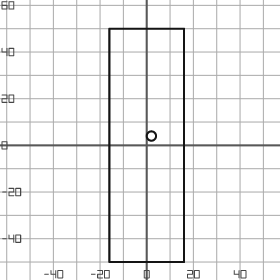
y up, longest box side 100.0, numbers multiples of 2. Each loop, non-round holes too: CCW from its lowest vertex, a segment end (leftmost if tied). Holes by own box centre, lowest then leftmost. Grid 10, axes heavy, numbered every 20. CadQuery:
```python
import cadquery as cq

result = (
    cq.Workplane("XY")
    .moveTo(-16.0, -50.0)
    .lineTo(16.0, -50.0)
    .lineTo(16.0, 50.0)
    .lineTo(-16.0, 50.0)
    .close()
    .moveTo(2.0, 4.0)
    .circle(2.0)
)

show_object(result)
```